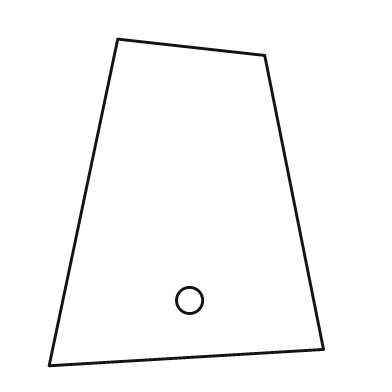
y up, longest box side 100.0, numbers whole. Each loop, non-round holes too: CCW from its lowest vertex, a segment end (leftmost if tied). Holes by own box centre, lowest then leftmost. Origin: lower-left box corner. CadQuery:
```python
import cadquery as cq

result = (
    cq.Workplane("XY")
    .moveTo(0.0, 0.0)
    .lineTo(84.0, 5.0)
    .lineTo(66.0, 95.0)
    .lineTo(21.0, 100.0)
    .close()
    .moveTo(43.0, 20.0)
    .circle(4.0)
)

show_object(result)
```